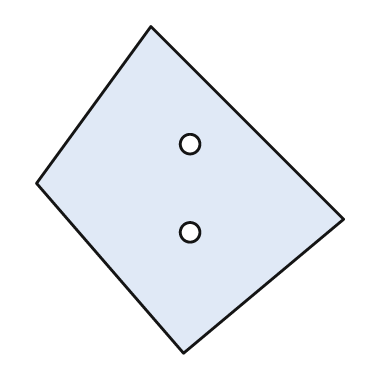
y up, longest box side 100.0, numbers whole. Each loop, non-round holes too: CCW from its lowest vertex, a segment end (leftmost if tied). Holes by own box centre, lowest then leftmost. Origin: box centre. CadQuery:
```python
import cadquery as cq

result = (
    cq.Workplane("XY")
    .moveTo(-2.0, -50.0)
    .lineTo(47.0, -9.0)
    .lineTo(-12.0, 50.0)
    .lineTo(-47.0, 2.0)
    .close()
    .moveTo(0.0, -13.0)
    .circle(3.0)
    .moveTo(0.0, 14.0)
    .circle(3.0)
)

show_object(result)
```